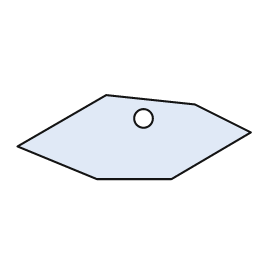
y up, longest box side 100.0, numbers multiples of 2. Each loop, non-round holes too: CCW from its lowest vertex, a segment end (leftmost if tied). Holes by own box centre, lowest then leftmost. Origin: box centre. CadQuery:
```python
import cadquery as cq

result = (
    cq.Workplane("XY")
    .moveTo(-16.0, -18.0)
    .lineTo(16.0, -18.0)
    .lineTo(50.0, 2.0)
    .lineTo(26.0, 14.0)
    .lineTo(-12.0, 18.0)
    .lineTo(-50.0, -4.0)
    .close()
    .moveTo(4.0, 8.0)
    .circle(4.0)
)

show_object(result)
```